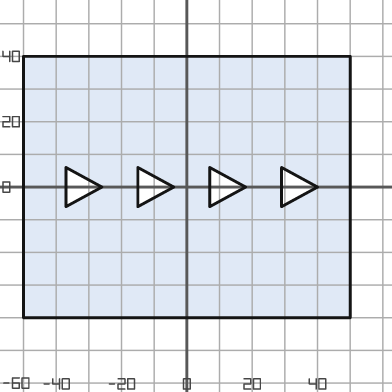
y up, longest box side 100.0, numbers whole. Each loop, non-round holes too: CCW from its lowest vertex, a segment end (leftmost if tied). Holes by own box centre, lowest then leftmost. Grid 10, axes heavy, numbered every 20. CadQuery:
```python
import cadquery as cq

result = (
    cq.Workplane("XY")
    .moveTo(-50.0, -40.0)
    .lineTo(50.0, -40.0)
    .lineTo(50.0, 40.0)
    .lineTo(-50.0, 40.0)
    .close()
    .moveTo(-37.0, -6.0)
    .lineTo(-26.0, 0.0)
    .lineTo(-37.0, 6.0)
    .close()
    .moveTo(-15.0, -6.0)
    .lineTo(-4.0, 0.0)
    .lineTo(-15.0, 6.0)
    .close()
    .moveTo(7.0, -6.0)
    .lineTo(18.0, 0.0)
    .lineTo(7.0, 6.0)
    .close()
    .moveTo(29.0, -6.0)
    .lineTo(40.0, 0.0)
    .lineTo(29.0, 6.0)
    .close()
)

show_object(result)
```